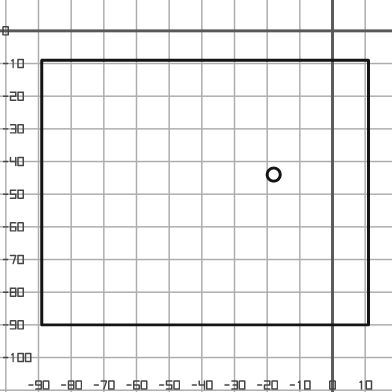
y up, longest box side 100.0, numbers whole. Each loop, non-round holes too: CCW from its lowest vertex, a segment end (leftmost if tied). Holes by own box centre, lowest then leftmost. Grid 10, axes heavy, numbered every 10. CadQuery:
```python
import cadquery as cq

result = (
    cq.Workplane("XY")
    .moveTo(-89.0, -90.0)
    .lineTo(11.0, -90.0)
    .lineTo(11.0, -9.0)
    .lineTo(-89.0, -9.0)
    .close()
    .moveTo(-18.0, -44.0)
    .circle(2.0)
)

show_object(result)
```